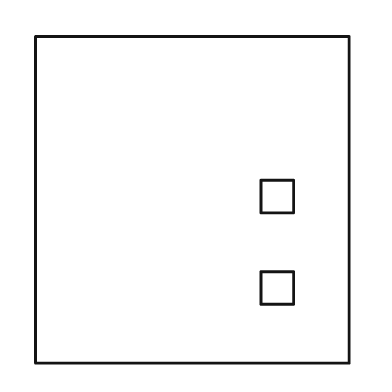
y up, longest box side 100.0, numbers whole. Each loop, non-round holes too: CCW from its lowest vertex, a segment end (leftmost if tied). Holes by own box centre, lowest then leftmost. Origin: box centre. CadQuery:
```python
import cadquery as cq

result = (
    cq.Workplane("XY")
    .moveTo(-48.0, -50.0)
    .lineTo(48.0, -50.0)
    .lineTo(48.0, 50.0)
    .lineTo(-48.0, 50.0)
    .close()
    .moveTo(21.0, -32.0)
    .lineTo(31.0, -32.0)
    .lineTo(31.0, -22.0)
    .lineTo(21.0, -22.0)
    .close()
    .moveTo(21.0, -4.0)
    .lineTo(31.0, -4.0)
    .lineTo(31.0, 6.0)
    .lineTo(21.0, 6.0)
    .close()
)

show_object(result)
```